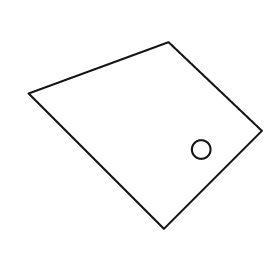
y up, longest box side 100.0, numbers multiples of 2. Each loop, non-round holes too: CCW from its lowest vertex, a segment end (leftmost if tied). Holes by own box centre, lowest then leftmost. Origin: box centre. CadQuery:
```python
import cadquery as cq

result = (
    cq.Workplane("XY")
    .moveTo(8.0, -40.0)
    .lineTo(50.0, 2.0)
    .lineTo(10.0, 40.0)
    .lineTo(-50.0, 18.0)
    .close()
    .moveTo(24.0, -6.0)
    .circle(4.0)
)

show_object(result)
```